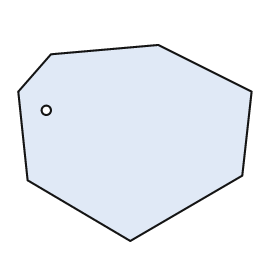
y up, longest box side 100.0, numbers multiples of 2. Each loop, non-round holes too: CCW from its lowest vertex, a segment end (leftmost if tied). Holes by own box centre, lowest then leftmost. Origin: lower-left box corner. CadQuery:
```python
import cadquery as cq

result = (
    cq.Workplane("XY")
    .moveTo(48.0, 0.0)
    .lineTo(96.0, 28.0)
    .lineTo(100.0, 64.0)
    .lineTo(60.0, 84.0)
    .lineTo(14.0, 80.0)
    .lineTo(0.0, 64.0)
    .lineTo(4.0, 26.0)
    .close()
    .moveTo(12.0, 56.0)
    .circle(2.0)
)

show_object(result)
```